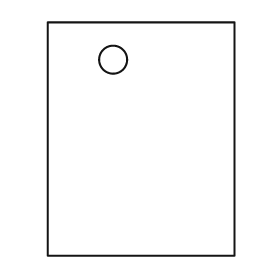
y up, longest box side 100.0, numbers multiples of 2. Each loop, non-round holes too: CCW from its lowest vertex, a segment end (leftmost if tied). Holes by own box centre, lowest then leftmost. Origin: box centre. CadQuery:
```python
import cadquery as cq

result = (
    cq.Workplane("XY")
    .moveTo(-40.0, -50.0)
    .lineTo(40.0, -50.0)
    .lineTo(40.0, 50.0)
    .lineTo(-40.0, 50.0)
    .close()
    .moveTo(-12.0, 34.0)
    .circle(6.0)
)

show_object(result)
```